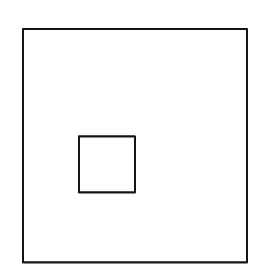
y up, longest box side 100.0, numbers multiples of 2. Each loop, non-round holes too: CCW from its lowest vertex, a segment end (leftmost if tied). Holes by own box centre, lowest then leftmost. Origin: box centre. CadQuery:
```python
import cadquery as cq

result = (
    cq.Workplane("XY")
    .moveTo(-48.0, -50.0)
    .lineTo(48.0, -50.0)
    .lineTo(48.0, 50.0)
    .lineTo(-48.0, 50.0)
    .close()
    .moveTo(-24.0, -20.0)
    .lineTo(0.0, -20.0)
    .lineTo(0.0, 4.0)
    .lineTo(-24.0, 4.0)
    .close()
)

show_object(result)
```